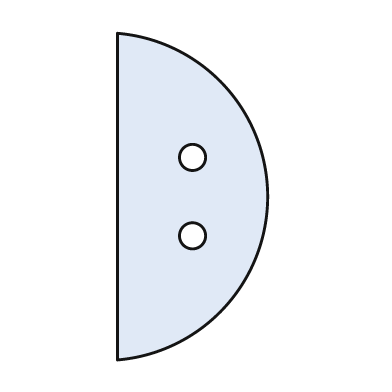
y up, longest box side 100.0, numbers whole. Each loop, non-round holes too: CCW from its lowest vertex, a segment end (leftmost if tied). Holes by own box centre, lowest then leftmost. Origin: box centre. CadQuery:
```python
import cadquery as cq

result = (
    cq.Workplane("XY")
    .moveTo(-23.0, -50.0)
    .threePointArc((23.0, 0.0), (-23.0, 50.0))
    .close()
    .moveTo(0.0, -12.0)
    .circle(4.0)
    .moveTo(0.0, 12.0)
    .circle(4.0)
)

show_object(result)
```